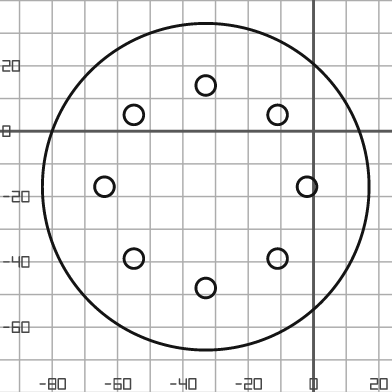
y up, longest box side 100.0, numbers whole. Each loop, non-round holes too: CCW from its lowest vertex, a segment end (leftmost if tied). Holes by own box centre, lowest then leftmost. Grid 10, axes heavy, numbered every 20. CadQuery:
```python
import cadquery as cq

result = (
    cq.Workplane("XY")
    .moveTo(-33.0, -17.0)
    .circle(50.0)
    .moveTo(-33.0, -48.0)
    .circle(3.0)
    .moveTo(-55.0, -39.0)
    .circle(3.0)
    .moveTo(-11.0, -39.0)
    .circle(3.0)
    .moveTo(-64.0, -17.0)
    .circle(3.0)
    .moveTo(-2.0, -17.0)
    .circle(3.0)
    .moveTo(-55.0, 5.0)
    .circle(3.0)
    .moveTo(-11.0, 5.0)
    .circle(3.0)
    .moveTo(-33.0, 14.0)
    .circle(3.0)
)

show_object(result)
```